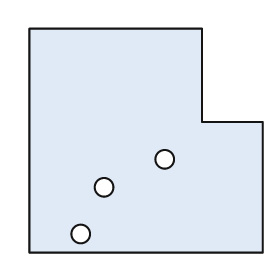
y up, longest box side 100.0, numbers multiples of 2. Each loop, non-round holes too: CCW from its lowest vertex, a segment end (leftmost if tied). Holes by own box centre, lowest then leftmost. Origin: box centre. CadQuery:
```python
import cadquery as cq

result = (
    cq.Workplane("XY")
    .moveTo(-50.0, -48.0)
    .lineTo(50.0, -48.0)
    .lineTo(50.0, 8.0)
    .lineTo(24.0, 8.0)
    .lineTo(24.0, 48.0)
    .lineTo(-50.0, 48.0)
    .close()
    .moveTo(-28.0, -40.0)
    .circle(4.0)
    .moveTo(-18.0, -20.0)
    .circle(4.0)
    .moveTo(8.0, -8.0)
    .circle(4.0)
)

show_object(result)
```